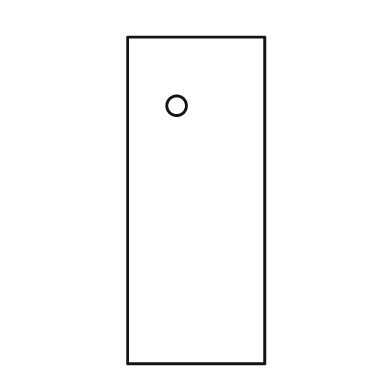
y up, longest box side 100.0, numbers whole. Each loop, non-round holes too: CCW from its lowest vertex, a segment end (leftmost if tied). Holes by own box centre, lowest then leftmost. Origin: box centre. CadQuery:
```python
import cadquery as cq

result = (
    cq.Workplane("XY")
    .moveTo(-21.0, -50.0)
    .lineTo(21.0, -50.0)
    .lineTo(21.0, 50.0)
    .lineTo(-21.0, 50.0)
    .close()
    .moveTo(-6.0, 29.0)
    .circle(3.0)
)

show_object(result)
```